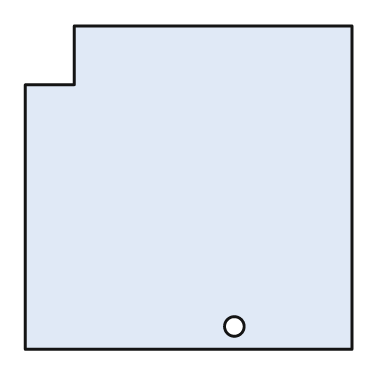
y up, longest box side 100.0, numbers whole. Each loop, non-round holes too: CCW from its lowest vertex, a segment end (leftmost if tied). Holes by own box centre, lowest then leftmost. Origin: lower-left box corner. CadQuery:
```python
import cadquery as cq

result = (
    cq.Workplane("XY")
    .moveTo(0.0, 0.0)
    .lineTo(100.0, 0.0)
    .lineTo(100.0, 99.0)
    .lineTo(15.0, 99.0)
    .lineTo(15.0, 81.0)
    .lineTo(0.0, 81.0)
    .close()
    .moveTo(64.0, 7.0)
    .circle(3.0)
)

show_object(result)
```